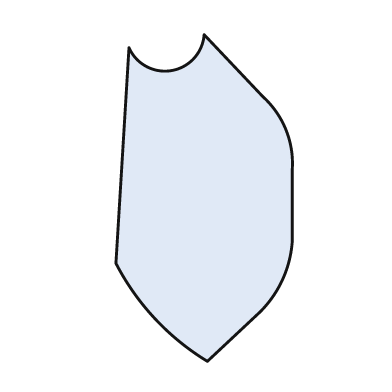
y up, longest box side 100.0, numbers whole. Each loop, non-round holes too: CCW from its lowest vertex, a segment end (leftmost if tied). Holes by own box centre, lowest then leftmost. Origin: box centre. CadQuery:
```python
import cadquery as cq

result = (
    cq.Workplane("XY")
    .moveTo(1.0, -50.0)
    .lineTo(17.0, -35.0)
    .threePointArc((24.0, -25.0), (27.0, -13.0))
    .lineTo(27.0, 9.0)
    .threePointArc((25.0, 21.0), (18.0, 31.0))
    .lineTo(0.0, 50.0)
    .threePointArc((-10.0, 39.0), (-23.0, 46.0))
    .lineTo(-27.0, -20.0)
    .threePointArc((-15.0, -37.0), (1.0, -50.0))
    .close()
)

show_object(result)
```